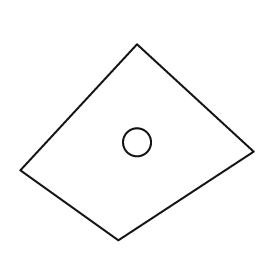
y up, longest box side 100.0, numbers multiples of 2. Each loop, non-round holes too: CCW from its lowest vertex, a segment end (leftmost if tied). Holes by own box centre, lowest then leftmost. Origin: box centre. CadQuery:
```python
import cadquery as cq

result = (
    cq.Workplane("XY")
    .moveTo(-8.0, -42.0)
    .lineTo(50.0, -4.0)
    .lineTo(0.0, 42.0)
    .lineTo(-50.0, -12.0)
    .close()
    .moveTo(0.0, 0.0)
    .circle(6.0)
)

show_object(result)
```